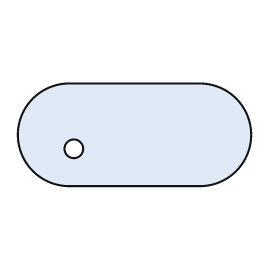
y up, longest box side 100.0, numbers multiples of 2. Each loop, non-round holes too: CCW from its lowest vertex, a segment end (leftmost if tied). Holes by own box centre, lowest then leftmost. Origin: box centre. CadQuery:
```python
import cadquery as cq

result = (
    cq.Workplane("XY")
    .moveTo(-28.0, -22.0)
    .lineTo(28.0, -22.0)
    .threePointArc((50.0, 0.0), (28.0, 22.0))
    .lineTo(-28.0, 22.0)
    .threePointArc((-50.0, 0.0), (-28.0, -22.0))
    .close()
    .moveTo(-26.0, -6.0)
    .circle(4.0)
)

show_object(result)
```